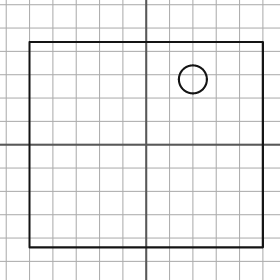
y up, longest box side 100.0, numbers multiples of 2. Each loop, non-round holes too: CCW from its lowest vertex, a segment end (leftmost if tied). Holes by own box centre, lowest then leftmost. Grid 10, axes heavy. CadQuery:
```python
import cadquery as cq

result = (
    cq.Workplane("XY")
    .moveTo(-50.0, -44.0)
    .lineTo(50.0, -44.0)
    .lineTo(50.0, 44.0)
    .lineTo(-50.0, 44.0)
    .close()
    .moveTo(20.0, 28.0)
    .circle(6.0)
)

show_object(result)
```